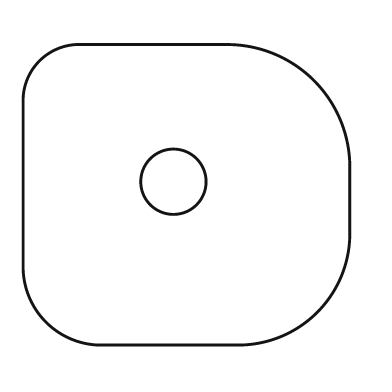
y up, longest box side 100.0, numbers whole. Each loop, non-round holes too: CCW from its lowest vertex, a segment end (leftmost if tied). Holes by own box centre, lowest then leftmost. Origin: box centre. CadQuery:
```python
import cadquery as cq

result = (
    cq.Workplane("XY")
    .moveTo(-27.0, -46.0)
    .lineTo(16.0, -46.0)
    .threePointArc((40.0, -36.0), (50.0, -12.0))
    .lineTo(50.0, 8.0)
    .threePointArc((39.0, 35.0), (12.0, 46.0))
    .lineTo(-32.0, 46.0)
    .threePointArc((-45.0, 41.0), (-50.0, 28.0))
    .lineTo(-50.0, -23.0)
    .threePointArc((-43.0, -39.0), (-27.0, -46.0))
    .close()
    .moveTo(-4.0, 4.0)
    .circle(10.0)
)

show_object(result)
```